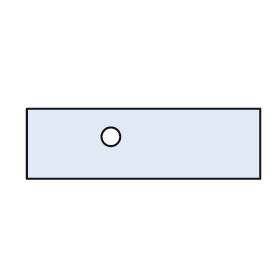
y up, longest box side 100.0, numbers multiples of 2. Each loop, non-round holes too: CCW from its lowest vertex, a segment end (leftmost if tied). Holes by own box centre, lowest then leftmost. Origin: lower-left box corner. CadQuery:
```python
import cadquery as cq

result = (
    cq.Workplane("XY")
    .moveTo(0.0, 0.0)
    .lineTo(100.0, 0.0)
    .lineTo(100.0, 30.0)
    .lineTo(0.0, 30.0)
    .close()
    .moveTo(36.0, 18.0)
    .circle(4.0)
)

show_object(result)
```